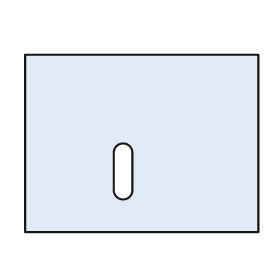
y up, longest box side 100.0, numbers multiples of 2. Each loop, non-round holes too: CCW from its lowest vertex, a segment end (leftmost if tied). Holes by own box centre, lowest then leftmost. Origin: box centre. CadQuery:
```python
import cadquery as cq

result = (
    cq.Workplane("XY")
    .moveTo(-50.0, -38.0)
    .lineTo(50.0, -38.0)
    .lineTo(50.0, 38.0)
    .lineTo(-50.0, 38.0)
    .close()
    .moveTo(-12.0, -20.0)
    .threePointArc((-8.0, -24.0), (-4.0, -20.0))
    .lineTo(-4.0, -4.0)
    .threePointArc((-8.0, 0.0), (-12.0, -4.0))
    .close()
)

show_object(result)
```